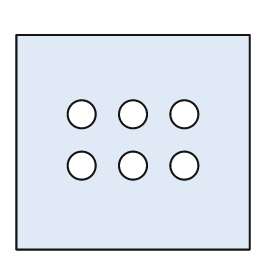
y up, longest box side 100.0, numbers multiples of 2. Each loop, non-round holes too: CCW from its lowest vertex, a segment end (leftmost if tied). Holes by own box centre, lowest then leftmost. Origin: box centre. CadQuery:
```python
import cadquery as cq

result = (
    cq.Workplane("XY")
    .moveTo(-50.0, -46.0)
    .lineTo(50.0, -46.0)
    .lineTo(50.0, 46.0)
    .lineTo(-50.0, 46.0)
    .close()
    .moveTo(-22.0, -10.0)
    .circle(6.0)
    .moveTo(0.0, -10.0)
    .circle(6.0)
    .moveTo(22.0, -10.0)
    .circle(6.0)
    .moveTo(-22.0, 12.0)
    .circle(6.0)
    .moveTo(0.0, 12.0)
    .circle(6.0)
    .moveTo(22.0, 12.0)
    .circle(6.0)
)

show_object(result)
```